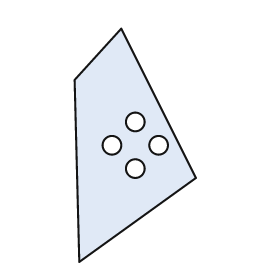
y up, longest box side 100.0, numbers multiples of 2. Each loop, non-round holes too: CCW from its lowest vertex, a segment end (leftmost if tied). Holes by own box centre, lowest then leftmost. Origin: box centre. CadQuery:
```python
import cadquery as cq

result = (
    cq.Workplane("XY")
    .moveTo(-24.0, -50.0)
    .lineTo(26.0, -14.0)
    .lineTo(-6.0, 50.0)
    .lineTo(-26.0, 28.0)
    .close()
    .moveTo(0.0, -10.0)
    .circle(4.0)
    .moveTo(-10.0, 0.0)
    .circle(4.0)
    .moveTo(10.0, 0.0)
    .circle(4.0)
    .moveTo(0.0, 10.0)
    .circle(4.0)
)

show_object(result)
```